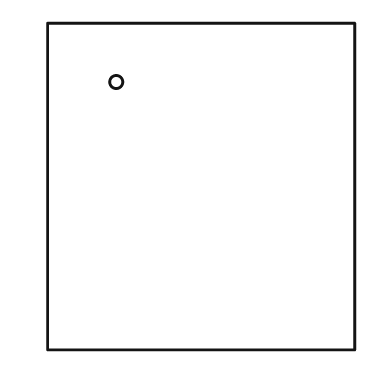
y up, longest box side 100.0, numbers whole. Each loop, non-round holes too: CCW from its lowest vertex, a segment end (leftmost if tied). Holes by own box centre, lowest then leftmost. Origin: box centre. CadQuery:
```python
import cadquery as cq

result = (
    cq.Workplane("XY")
    .moveTo(-47.0, -50.0)
    .lineTo(47.0, -50.0)
    .lineTo(47.0, 50.0)
    .lineTo(-47.0, 50.0)
    .close()
    .moveTo(-26.0, 32.0)
    .circle(2.0)
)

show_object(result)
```